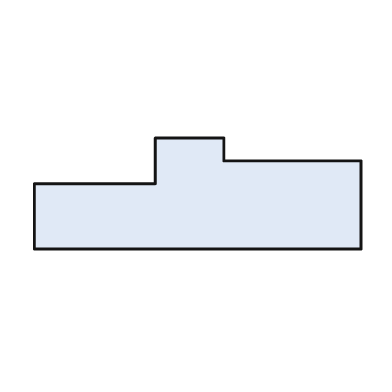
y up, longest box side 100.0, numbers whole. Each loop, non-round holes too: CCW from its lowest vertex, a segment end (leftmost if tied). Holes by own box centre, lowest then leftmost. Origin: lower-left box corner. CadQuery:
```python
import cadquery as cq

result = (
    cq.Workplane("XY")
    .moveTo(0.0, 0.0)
    .lineTo(100.0, 0.0)
    .lineTo(100.0, 27.0)
    .lineTo(58.0, 27.0)
    .lineTo(58.0, 34.0)
    .lineTo(37.0, 34.0)
    .lineTo(37.0, 20.0)
    .lineTo(0.0, 20.0)
    .close()
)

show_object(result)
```